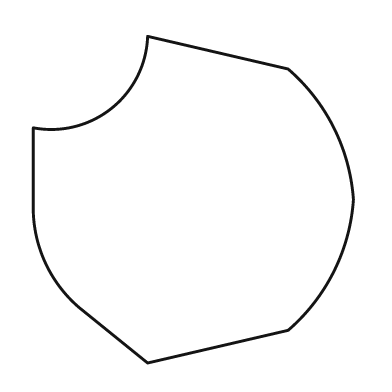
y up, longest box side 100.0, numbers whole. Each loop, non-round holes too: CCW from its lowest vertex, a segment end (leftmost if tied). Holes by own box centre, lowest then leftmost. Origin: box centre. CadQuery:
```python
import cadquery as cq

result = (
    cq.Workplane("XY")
    .moveTo(-14.0, -50.0)
    .lineTo(29.0, -40.0)
    .threePointArc((43.0, -22.0), (49.0, 0.0))
    .threePointArc((43.0, 22.0), (29.0, 40.0))
    .lineTo(-14.0, 50.0)
    .threePointArc((-25.0, 28.0), (-49.0, 22.0))
    .lineTo(-49.0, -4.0)
    .threePointArc((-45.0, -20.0), (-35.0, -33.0))
    .close()
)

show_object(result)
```